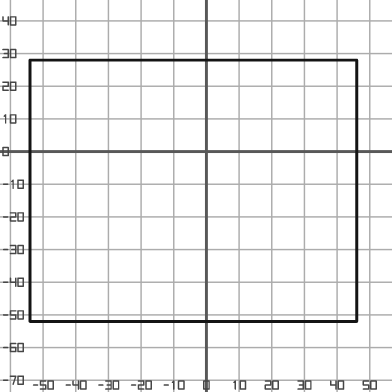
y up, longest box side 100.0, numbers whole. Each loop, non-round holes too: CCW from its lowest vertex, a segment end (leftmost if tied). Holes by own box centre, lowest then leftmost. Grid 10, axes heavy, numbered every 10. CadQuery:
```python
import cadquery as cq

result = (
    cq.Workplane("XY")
    .moveTo(-54.0, -52.0)
    .lineTo(46.0, -52.0)
    .lineTo(46.0, 28.0)
    .lineTo(-54.0, 28.0)
    .close()
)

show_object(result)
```